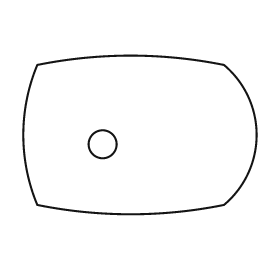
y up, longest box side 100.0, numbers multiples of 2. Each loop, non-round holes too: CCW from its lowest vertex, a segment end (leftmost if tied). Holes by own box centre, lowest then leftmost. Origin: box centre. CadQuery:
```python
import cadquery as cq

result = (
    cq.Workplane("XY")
    .moveTo(-44.0, -30.0)
    .threePointArc((-4.0, -34.0), (36.0, -30.0))
    .threePointArc((50.0, 0.0), (36.0, 30.0))
    .threePointArc((-4.0, 34.0), (-44.0, 30.0))
    .threePointArc((-50.0, 0.0), (-44.0, -30.0))
    .close()
    .moveTo(-16.0, -4.0)
    .circle(6.0)
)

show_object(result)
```